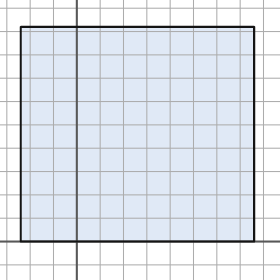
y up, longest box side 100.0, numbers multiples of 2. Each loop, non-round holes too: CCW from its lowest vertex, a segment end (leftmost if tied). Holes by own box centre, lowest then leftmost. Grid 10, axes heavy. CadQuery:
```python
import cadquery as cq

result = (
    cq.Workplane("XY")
    .moveTo(-24.0, 0.0)
    .lineTo(76.0, 0.0)
    .lineTo(76.0, 92.0)
    .lineTo(-24.0, 92.0)
    .close()
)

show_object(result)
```